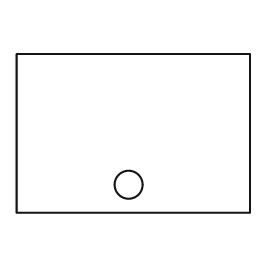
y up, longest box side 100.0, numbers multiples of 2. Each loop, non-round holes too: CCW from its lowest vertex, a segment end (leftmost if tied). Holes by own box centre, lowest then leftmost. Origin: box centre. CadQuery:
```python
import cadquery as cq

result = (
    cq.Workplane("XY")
    .moveTo(-50.0, -34.0)
    .lineTo(50.0, -34.0)
    .lineTo(50.0, 34.0)
    .lineTo(-50.0, 34.0)
    .close()
    .moveTo(-2.0, -22.0)
    .circle(6.0)
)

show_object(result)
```